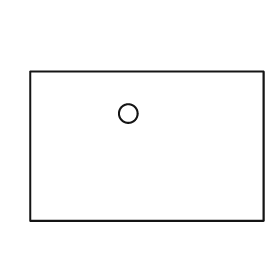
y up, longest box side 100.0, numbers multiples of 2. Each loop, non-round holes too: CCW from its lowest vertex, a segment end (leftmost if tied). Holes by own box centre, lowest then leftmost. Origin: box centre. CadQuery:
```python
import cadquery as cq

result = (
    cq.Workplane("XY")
    .moveTo(-50.0, -32.0)
    .lineTo(50.0, -32.0)
    .lineTo(50.0, 32.0)
    .lineTo(-50.0, 32.0)
    .close()
    .moveTo(-8.0, 14.0)
    .circle(4.0)
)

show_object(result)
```